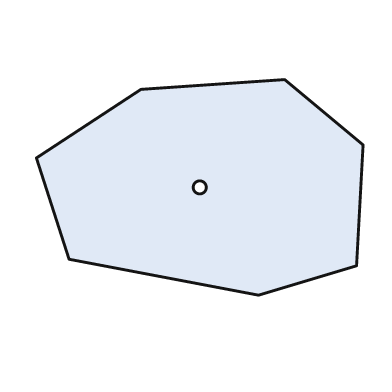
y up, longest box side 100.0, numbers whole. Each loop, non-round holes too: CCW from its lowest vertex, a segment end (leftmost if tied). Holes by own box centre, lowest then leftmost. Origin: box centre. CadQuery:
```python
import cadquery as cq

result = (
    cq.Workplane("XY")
    .moveTo(18.0, -33.0)
    .lineTo(48.0, -24.0)
    .lineTo(50.0, 13.0)
    .lineTo(26.0, 33.0)
    .lineTo(-18.0, 30.0)
    .lineTo(-50.0, 9.0)
    .lineTo(-40.0, -22.0)
    .close()
    .moveTo(0.0, 0.0)
    .circle(2.0)
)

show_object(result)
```